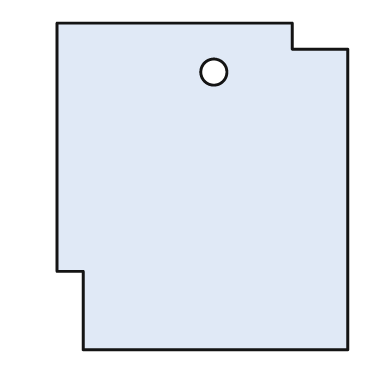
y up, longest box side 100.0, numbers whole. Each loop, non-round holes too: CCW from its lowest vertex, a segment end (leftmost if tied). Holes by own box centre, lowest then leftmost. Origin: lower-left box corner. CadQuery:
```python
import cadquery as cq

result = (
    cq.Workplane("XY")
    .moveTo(8.0, 0.0)
    .lineTo(89.0, 0.0)
    .lineTo(89.0, 92.0)
    .lineTo(72.0, 92.0)
    .lineTo(72.0, 100.0)
    .lineTo(0.0, 100.0)
    .lineTo(0.0, 24.0)
    .lineTo(8.0, 24.0)
    .close()
    .moveTo(48.0, 85.0)
    .circle(4.0)
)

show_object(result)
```